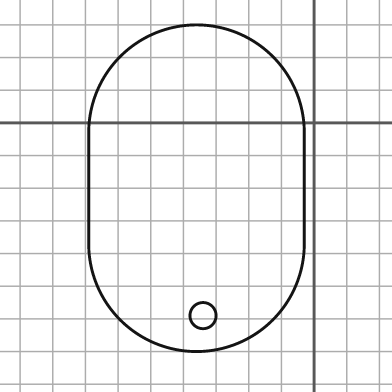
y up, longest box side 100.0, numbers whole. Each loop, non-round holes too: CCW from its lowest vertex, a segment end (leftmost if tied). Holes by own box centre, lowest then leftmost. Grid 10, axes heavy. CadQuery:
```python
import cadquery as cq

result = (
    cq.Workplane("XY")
    .moveTo(-69.0, -37.0)
    .threePointArc((-36.0, -70.0), (-3.0, -37.0))
    .lineTo(-3.0, -3.0)
    .threePointArc((-36.0, 30.0), (-69.0, -3.0))
    .close()
    .moveTo(-34.0, -59.0)
    .circle(4.0)
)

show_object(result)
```